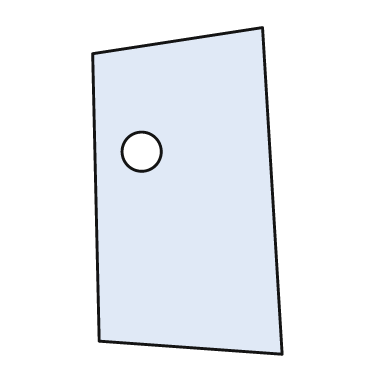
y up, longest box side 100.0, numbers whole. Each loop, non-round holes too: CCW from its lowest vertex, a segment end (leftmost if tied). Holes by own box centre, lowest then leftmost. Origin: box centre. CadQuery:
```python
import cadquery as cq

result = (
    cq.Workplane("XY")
    .moveTo(29.0, -50.0)
    .lineTo(23.0, 50.0)
    .lineTo(-29.0, 42.0)
    .lineTo(-27.0, -46.0)
    .close()
    .moveTo(-14.0, 12.0)
    .circle(6.0)
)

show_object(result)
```